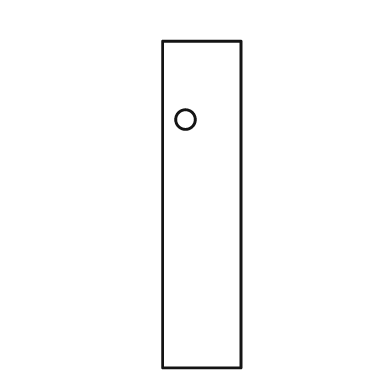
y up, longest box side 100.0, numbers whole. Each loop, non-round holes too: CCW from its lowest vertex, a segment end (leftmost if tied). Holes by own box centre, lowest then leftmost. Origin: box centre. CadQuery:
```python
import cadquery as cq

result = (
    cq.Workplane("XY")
    .moveTo(-12.0, -50.0)
    .lineTo(12.0, -50.0)
    .lineTo(12.0, 50.0)
    .lineTo(-12.0, 50.0)
    .close()
    .moveTo(-5.0, 26.0)
    .circle(3.0)
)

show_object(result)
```